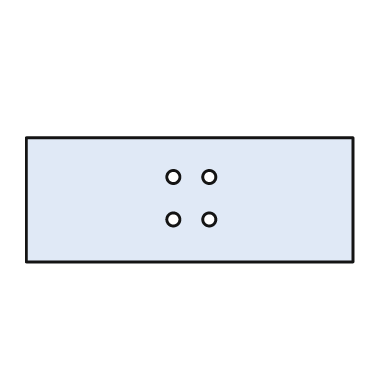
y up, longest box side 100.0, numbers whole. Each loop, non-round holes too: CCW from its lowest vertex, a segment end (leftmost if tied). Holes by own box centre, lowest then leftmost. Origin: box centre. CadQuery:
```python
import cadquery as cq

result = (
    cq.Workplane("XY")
    .moveTo(-50.0, -19.0)
    .lineTo(50.0, -19.0)
    .lineTo(50.0, 19.0)
    .lineTo(-50.0, 19.0)
    .close()
    .moveTo(-5.0, -6.0)
    .circle(2.0)
    .moveTo(6.0, -6.0)
    .circle(2.0)
    .moveTo(-5.0, 7.0)
    .circle(2.0)
    .moveTo(6.0, 7.0)
    .circle(2.0)
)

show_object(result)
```